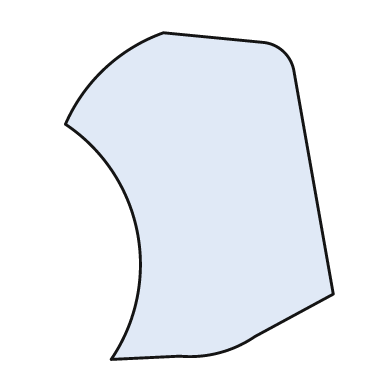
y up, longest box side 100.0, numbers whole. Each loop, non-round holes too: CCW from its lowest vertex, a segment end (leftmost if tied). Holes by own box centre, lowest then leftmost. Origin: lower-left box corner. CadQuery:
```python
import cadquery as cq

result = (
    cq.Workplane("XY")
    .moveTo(14.0, 0.0)
    .lineTo(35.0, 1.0)
    .threePointArc((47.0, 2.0), (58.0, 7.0))
    .lineTo(82.0, 20.0)
    .lineTo(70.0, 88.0)
    .threePointArc((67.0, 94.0), (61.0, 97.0))
    .lineTo(30.0, 100.0)
    .threePointArc((12.0, 89.0), (0.0, 72.0))
    .threePointArc((22.0, 39.0), (14.0, 0.0))
    .close()
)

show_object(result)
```